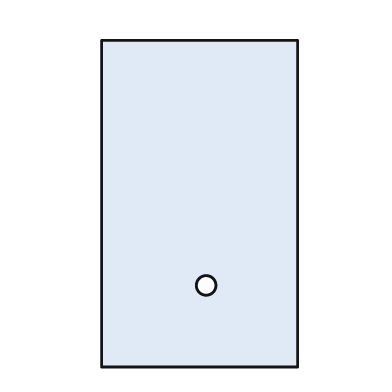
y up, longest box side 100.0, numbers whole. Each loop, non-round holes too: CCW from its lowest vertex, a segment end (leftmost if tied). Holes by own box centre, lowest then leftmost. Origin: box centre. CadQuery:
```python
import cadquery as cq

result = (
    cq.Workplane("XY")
    .moveTo(-30.0, -50.0)
    .lineTo(30.0, -50.0)
    .lineTo(30.0, 50.0)
    .lineTo(-30.0, 50.0)
    .close()
    .moveTo(2.0, -25.0)
    .circle(3.0)
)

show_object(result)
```